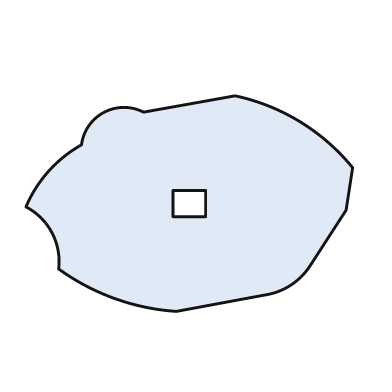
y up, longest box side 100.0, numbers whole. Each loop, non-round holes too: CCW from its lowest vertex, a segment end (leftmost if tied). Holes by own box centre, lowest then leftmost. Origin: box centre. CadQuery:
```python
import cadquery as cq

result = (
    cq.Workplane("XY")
    .moveTo(-4.0, -33.0)
    .lineTo(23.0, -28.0)
    .threePointArc((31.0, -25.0), (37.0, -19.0))
    .lineTo(48.0, -2.0)
    .lineTo(50.0, 11.0)
    .threePointArc((34.0, 25.0), (14.0, 33.0))
    .lineTo(-14.0, 28.0)
    .threePointArc((-26.0, 28.0), (-33.0, 18.0))
    .threePointArc((-43.0, 10.0), (-50.0, -1.0))
    .threePointArc((-42.0, -9.0), (-40.0, -20.0))
    .threePointArc((-23.0, -29.0), (-4.0, -33.0))
    .close()
    .moveTo(-5.0, -4.0)
    .lineTo(5.0, -4.0)
    .lineTo(5.0, 4.0)
    .lineTo(-5.0, 4.0)
    .close()
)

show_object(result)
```